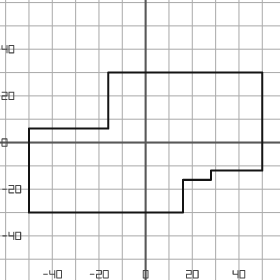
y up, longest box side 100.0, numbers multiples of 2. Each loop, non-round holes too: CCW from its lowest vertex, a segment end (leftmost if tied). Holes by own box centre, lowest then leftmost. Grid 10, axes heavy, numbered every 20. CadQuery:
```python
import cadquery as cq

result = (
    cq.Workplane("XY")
    .moveTo(-50.0, -30.0)
    .lineTo(16.0, -30.0)
    .lineTo(16.0, -16.0)
    .lineTo(28.0, -16.0)
    .lineTo(28.0, -12.0)
    .lineTo(50.0, -12.0)
    .lineTo(50.0, 30.0)
    .lineTo(-16.0, 30.0)
    .lineTo(-16.0, 6.0)
    .lineTo(-50.0, 6.0)
    .close()
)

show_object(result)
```